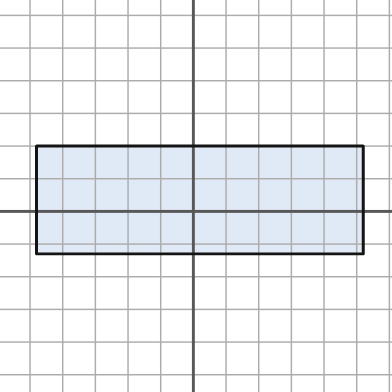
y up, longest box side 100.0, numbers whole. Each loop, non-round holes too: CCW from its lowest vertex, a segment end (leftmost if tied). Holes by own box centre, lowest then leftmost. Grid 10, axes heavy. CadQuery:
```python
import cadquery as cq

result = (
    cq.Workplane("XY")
    .moveTo(-48.0, -13.0)
    .lineTo(52.0, -13.0)
    .lineTo(52.0, 20.0)
    .lineTo(-48.0, 20.0)
    .close()
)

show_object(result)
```